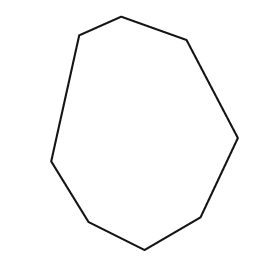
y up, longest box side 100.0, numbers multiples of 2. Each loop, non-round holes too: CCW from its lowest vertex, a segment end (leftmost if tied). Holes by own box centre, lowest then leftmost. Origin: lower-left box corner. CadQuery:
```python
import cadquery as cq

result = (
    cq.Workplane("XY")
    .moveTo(40.0, 0.0)
    .lineTo(64.0, 14.0)
    .lineTo(80.0, 48.0)
    .lineTo(58.0, 90.0)
    .lineTo(30.0, 100.0)
    .lineTo(12.0, 92.0)
    .lineTo(0.0, 38.0)
    .lineTo(16.0, 12.0)
    .close()
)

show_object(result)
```